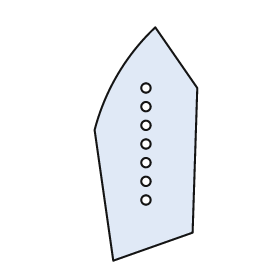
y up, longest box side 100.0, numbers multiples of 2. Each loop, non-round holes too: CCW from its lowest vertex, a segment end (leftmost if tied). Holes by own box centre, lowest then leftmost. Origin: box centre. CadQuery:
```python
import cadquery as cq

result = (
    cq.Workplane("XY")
    .moveTo(-14.0, -50.0)
    .lineTo(20.0, -38.0)
    .lineTo(22.0, 24.0)
    .lineTo(4.0, 50.0)
    .threePointArc((-12.0, 30.0), (-22.0, 6.0))
    .close()
    .moveTo(0.0, -24.0)
    .circle(2.0)
    .moveTo(0.0, -16.0)
    .circle(2.0)
    .moveTo(0.0, -8.0)
    .circle(2.0)
    .moveTo(0.0, 0.0)
    .circle(2.0)
    .moveTo(0.0, 8.0)
    .circle(2.0)
    .moveTo(0.0, 16.0)
    .circle(2.0)
    .moveTo(0.0, 24.0)
    .circle(2.0)
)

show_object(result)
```